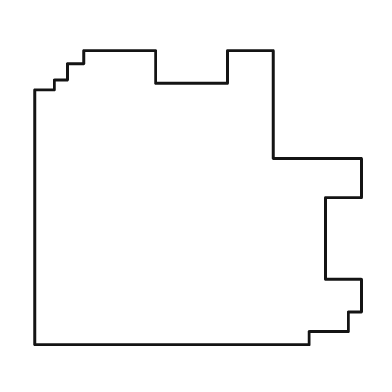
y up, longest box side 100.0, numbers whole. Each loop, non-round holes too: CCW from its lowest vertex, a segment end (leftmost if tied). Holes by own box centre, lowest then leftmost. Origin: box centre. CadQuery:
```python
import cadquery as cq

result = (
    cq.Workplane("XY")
    .moveTo(-50.0, -45.0)
    .lineTo(34.0, -45.0)
    .lineTo(34.0, -41.0)
    .lineTo(46.0, -41.0)
    .lineTo(46.0, -35.0)
    .lineTo(50.0, -35.0)
    .lineTo(50.0, -25.0)
    .lineTo(39.0, -25.0)
    .lineTo(39.0, 0.0)
    .lineTo(50.0, 0.0)
    .lineTo(50.0, 12.0)
    .lineTo(23.0, 12.0)
    .lineTo(23.0, 45.0)
    .lineTo(9.0, 45.0)
    .lineTo(9.0, 35.0)
    .lineTo(-13.0, 35.0)
    .lineTo(-13.0, 45.0)
    .lineTo(-35.0, 45.0)
    .lineTo(-35.0, 41.0)
    .lineTo(-40.0, 41.0)
    .lineTo(-40.0, 36.0)
    .lineTo(-44.0, 36.0)
    .lineTo(-44.0, 33.0)
    .lineTo(-50.0, 33.0)
    .close()
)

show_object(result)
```